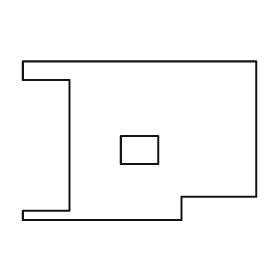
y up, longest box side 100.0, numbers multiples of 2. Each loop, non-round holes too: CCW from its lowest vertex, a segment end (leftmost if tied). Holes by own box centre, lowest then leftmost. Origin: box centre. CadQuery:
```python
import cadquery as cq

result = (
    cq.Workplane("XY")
    .moveTo(-50.0, -34.0)
    .lineTo(18.0, -34.0)
    .lineTo(18.0, -24.0)
    .lineTo(50.0, -24.0)
    .lineTo(50.0, 34.0)
    .lineTo(-50.0, 34.0)
    .lineTo(-50.0, 26.0)
    .lineTo(-30.0, 26.0)
    .lineTo(-30.0, -30.0)
    .lineTo(-50.0, -30.0)
    .close()
    .moveTo(-8.0, -10.0)
    .lineTo(8.0, -10.0)
    .lineTo(8.0, 2.0)
    .lineTo(-8.0, 2.0)
    .close()
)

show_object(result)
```